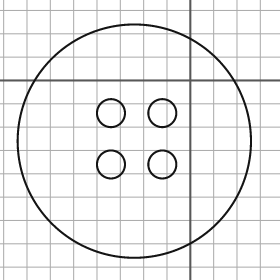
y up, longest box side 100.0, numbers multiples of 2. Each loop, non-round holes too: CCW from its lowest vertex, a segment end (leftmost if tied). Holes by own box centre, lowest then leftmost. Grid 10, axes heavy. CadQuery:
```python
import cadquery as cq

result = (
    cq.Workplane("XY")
    .moveTo(-24.0, -26.0)
    .circle(50.0)
    .moveTo(-34.0, -36.0)
    .circle(6.0)
    .moveTo(-12.0, -36.0)
    .circle(6.0)
    .moveTo(-34.0, -14.0)
    .circle(6.0)
    .moveTo(-12.0, -14.0)
    .circle(6.0)
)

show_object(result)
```